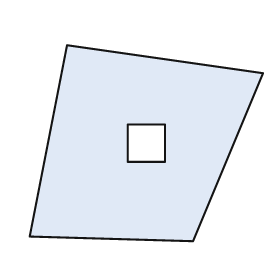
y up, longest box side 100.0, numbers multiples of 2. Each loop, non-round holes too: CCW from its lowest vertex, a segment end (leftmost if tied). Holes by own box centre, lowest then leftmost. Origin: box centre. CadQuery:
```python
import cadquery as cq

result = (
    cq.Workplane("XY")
    .moveTo(20.0, -42.0)
    .lineTo(50.0, 30.0)
    .lineTo(-34.0, 42.0)
    .lineTo(-50.0, -40.0)
    .close()
    .moveTo(-8.0, -8.0)
    .lineTo(8.0, -8.0)
    .lineTo(8.0, 8.0)
    .lineTo(-8.0, 8.0)
    .close()
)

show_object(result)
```